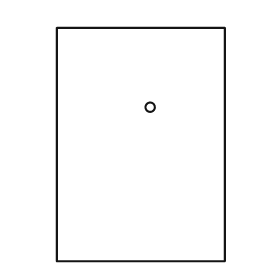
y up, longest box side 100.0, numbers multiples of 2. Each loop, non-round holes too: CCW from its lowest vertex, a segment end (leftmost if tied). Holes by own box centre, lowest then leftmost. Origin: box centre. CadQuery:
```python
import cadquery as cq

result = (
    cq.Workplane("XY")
    .moveTo(-36.0, -50.0)
    .lineTo(36.0, -50.0)
    .lineTo(36.0, 50.0)
    .lineTo(-36.0, 50.0)
    .close()
    .moveTo(4.0, 16.0)
    .circle(2.0)
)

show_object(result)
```